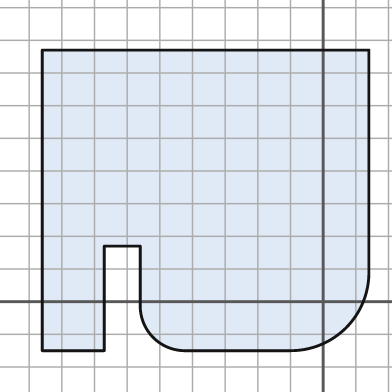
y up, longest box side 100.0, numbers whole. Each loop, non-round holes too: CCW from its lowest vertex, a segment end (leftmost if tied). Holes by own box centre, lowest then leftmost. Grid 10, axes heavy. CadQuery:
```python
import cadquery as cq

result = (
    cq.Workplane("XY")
    .moveTo(-86.0, -15.0)
    .lineTo(-67.0, -15.0)
    .lineTo(-67.0, 17.0)
    .lineTo(-56.0, 17.0)
    .lineTo(-56.0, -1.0)
    .threePointArc((-52.0, -11.0), (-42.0, -15.0))
    .lineTo(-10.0, -15.0)
    .threePointArc((7.0, -8.0), (14.0, 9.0))
    .lineTo(14.0, 77.0)
    .lineTo(-86.0, 77.0)
    .close()
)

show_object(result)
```